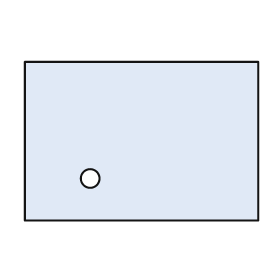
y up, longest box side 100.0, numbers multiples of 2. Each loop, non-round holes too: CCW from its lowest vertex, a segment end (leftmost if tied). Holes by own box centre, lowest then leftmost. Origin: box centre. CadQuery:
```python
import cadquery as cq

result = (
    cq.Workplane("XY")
    .moveTo(-50.0, -34.0)
    .lineTo(50.0, -34.0)
    .lineTo(50.0, 34.0)
    .lineTo(-50.0, 34.0)
    .close()
    .moveTo(-22.0, -16.0)
    .circle(4.0)
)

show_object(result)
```